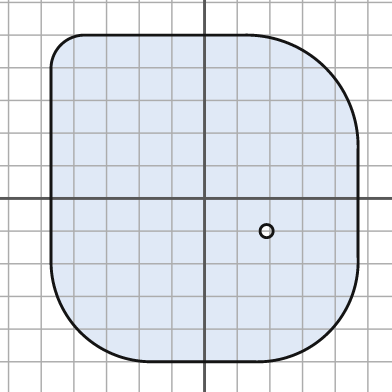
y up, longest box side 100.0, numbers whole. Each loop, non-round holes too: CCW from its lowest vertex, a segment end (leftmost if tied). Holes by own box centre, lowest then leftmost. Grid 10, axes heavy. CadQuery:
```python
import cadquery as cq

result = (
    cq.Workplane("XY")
    .moveTo(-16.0, -50.0)
    .lineTo(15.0, -50.0)
    .threePointArc((38.0, -41.0), (47.0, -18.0))
    .lineTo(47.0, 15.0)
    .threePointArc((37.0, 40.0), (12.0, 50.0))
    .lineTo(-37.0, 50.0)
    .threePointArc((-44.0, 47.0), (-47.0, 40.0))
    .lineTo(-47.0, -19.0)
    .threePointArc((-38.0, -41.0), (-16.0, -50.0))
    .close()
    .moveTo(19.0, -10.0)
    .circle(2.0)
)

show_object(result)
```